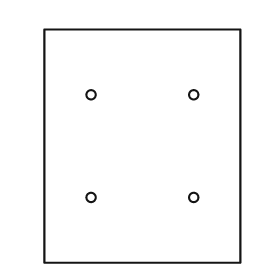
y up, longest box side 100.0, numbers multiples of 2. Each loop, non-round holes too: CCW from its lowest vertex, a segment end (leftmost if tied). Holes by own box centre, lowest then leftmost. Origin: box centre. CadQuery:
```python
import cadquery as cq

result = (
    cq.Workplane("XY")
    .moveTo(-42.0, -50.0)
    .lineTo(42.0, -50.0)
    .lineTo(42.0, 50.0)
    .lineTo(-42.0, 50.0)
    .close()
    .moveTo(-22.0, -22.0)
    .circle(2.0)
    .moveTo(22.0, -22.0)
    .circle(2.0)
    .moveTo(-22.0, 22.0)
    .circle(2.0)
    .moveTo(22.0, 22.0)
    .circle(2.0)
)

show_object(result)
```